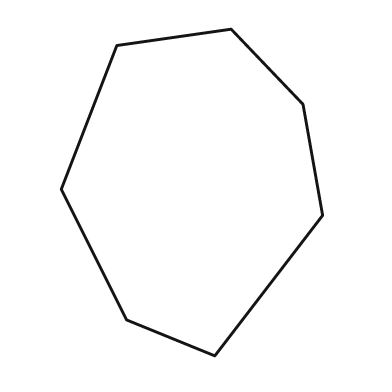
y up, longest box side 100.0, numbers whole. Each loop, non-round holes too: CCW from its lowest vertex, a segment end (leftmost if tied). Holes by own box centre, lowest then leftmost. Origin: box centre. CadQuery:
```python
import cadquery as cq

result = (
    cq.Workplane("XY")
    .moveTo(7.0, -50.0)
    .lineTo(40.0, -7.0)
    .lineTo(34.0, 27.0)
    .lineTo(12.0, 50.0)
    .lineTo(-23.0, 45.0)
    .lineTo(-40.0, 1.0)
    .lineTo(-20.0, -39.0)
    .close()
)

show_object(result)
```